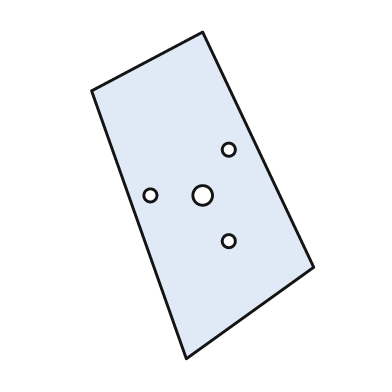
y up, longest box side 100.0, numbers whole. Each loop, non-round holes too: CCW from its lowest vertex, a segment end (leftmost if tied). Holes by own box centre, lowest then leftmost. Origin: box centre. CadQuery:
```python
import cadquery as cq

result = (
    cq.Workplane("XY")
    .moveTo(-5.0, -50.0)
    .lineTo(34.0, -22.0)
    .lineTo(0.0, 50.0)
    .lineTo(-34.0, 32.0)
    .close()
    .moveTo(8.0, -14.0)
    .circle(2.0)
    .moveTo(-16.0, 0.0)
    .circle(2.0)
    .moveTo(0.0, 0.0)
    .circle(3.0)
    .moveTo(8.0, 14.0)
    .circle(2.0)
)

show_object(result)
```